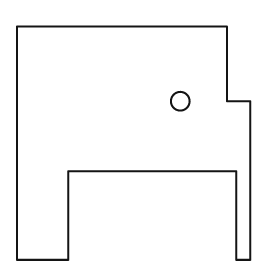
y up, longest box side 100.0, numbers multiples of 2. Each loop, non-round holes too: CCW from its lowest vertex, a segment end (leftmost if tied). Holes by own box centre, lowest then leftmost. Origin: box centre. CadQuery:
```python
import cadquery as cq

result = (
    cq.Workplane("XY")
    .moveTo(-50.0, -50.0)
    .lineTo(-28.0, -50.0)
    .lineTo(-28.0, -12.0)
    .lineTo(44.0, -12.0)
    .lineTo(44.0, -50.0)
    .lineTo(50.0, -50.0)
    .lineTo(50.0, 18.0)
    .lineTo(40.0, 18.0)
    .lineTo(40.0, 50.0)
    .lineTo(-50.0, 50.0)
    .close()
    .moveTo(20.0, 18.0)
    .circle(4.0)
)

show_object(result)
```